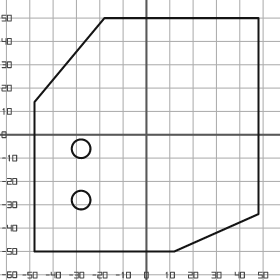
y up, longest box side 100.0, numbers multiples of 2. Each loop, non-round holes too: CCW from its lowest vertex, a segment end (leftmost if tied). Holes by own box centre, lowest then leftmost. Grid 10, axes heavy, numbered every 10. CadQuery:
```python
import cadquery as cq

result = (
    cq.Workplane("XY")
    .moveTo(-48.0, -50.0)
    .lineTo(12.0, -50.0)
    .lineTo(48.0, -34.0)
    .lineTo(48.0, 50.0)
    .lineTo(-18.0, 50.0)
    .lineTo(-48.0, 14.0)
    .close()
    .moveTo(-28.0, -28.0)
    .circle(4.0)
    .moveTo(-28.0, -6.0)
    .circle(4.0)
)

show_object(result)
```